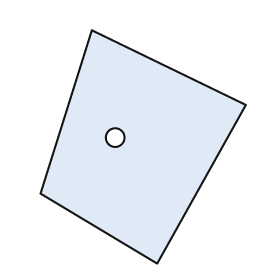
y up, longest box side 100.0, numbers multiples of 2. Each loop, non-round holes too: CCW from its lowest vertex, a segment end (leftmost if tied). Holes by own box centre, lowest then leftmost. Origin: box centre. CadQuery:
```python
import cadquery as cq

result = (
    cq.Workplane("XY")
    .moveTo(6.0, -50.0)
    .lineTo(44.0, 18.0)
    .lineTo(-22.0, 50.0)
    .lineTo(-44.0, -20.0)
    .close()
    .moveTo(-12.0, 4.0)
    .circle(4.0)
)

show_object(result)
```